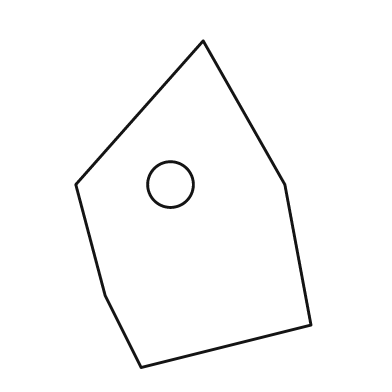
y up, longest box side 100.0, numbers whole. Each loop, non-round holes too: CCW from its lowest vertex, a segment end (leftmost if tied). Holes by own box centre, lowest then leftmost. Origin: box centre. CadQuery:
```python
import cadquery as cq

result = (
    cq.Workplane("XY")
    .moveTo(-16.0, -50.0)
    .lineTo(36.0, -37.0)
    .lineTo(28.0, 6.0)
    .lineTo(3.0, 50.0)
    .lineTo(-36.0, 6.0)
    .lineTo(-27.0, -28.0)
    .close()
    .moveTo(-7.0, 6.0)
    .circle(7.0)
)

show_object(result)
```